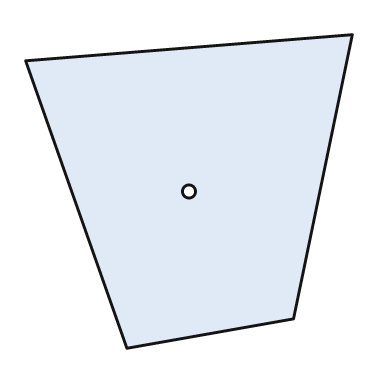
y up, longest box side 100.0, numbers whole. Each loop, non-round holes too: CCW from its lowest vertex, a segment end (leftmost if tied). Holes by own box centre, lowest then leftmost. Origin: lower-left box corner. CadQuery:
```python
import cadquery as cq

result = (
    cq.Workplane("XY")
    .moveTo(31.0, 0.0)
    .lineTo(82.0, 9.0)
    .lineTo(100.0, 96.0)
    .lineTo(0.0, 88.0)
    .close()
    .moveTo(50.0, 48.0)
    .circle(2.0)
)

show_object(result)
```